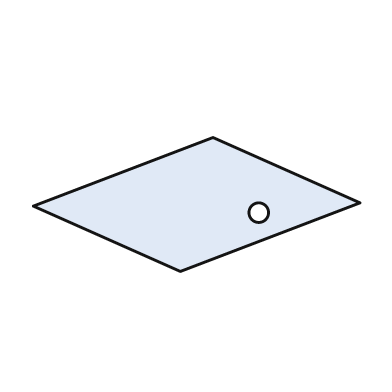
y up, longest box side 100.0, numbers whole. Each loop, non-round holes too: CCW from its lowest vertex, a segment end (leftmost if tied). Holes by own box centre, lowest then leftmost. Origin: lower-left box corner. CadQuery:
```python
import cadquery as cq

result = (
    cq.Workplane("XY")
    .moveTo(45.0, 0.0)
    .lineTo(100.0, 21.0)
    .lineTo(55.0, 41.0)
    .lineTo(0.0, 20.0)
    .close()
    .moveTo(69.0, 18.0)
    .circle(3.0)
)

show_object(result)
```